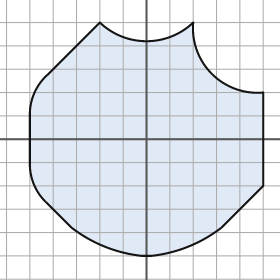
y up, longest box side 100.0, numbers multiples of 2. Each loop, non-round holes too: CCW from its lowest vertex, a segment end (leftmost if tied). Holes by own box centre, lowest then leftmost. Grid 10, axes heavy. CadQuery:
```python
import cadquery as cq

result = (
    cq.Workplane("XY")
    .moveTo(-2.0, -50.0)
    .lineTo(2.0, -50.0)
    .threePointArc((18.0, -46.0), (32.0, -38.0))
    .lineTo(50.0, -20.0)
    .lineTo(50.0, 20.0)
    .threePointArc((28.0, 28.0), (20.0, 50.0))
    .threePointArc((0.0, 42.0), (-20.0, 50.0))
    .lineTo(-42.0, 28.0)
    .threePointArc((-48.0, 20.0), (-50.0, 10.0))
    .lineTo(-50.0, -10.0)
    .threePointArc((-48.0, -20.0), (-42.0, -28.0))
    .lineTo(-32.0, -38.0)
    .threePointArc((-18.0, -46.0), (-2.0, -50.0))
    .close()
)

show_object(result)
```